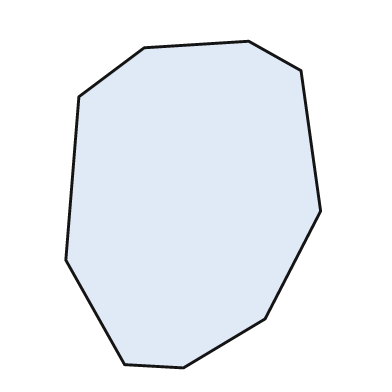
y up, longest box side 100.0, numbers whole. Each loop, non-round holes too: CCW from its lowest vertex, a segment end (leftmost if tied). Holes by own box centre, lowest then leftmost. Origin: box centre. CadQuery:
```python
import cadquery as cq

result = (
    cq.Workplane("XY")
    .moveTo(-3.0, -50.0)
    .lineTo(22.0, -35.0)
    .lineTo(39.0, -2.0)
    .lineTo(33.0, 41.0)
    .lineTo(17.0, 50.0)
    .lineTo(-15.0, 48.0)
    .lineTo(-35.0, 33.0)
    .lineTo(-39.0, -17.0)
    .lineTo(-21.0, -49.0)
    .close()
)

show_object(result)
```